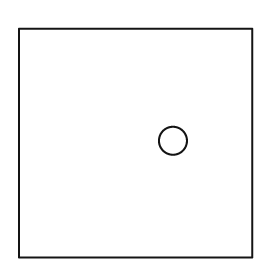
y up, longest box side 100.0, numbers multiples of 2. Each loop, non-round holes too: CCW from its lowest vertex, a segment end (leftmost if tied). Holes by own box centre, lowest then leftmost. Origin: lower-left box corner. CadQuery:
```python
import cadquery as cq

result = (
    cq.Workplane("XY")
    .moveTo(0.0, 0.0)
    .lineTo(100.0, 0.0)
    .lineTo(100.0, 98.0)
    .lineTo(0.0, 98.0)
    .close()
    .moveTo(66.0, 50.0)
    .circle(6.0)
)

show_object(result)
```